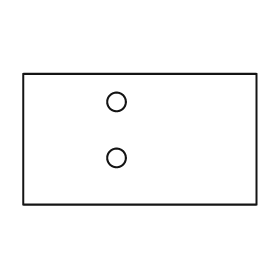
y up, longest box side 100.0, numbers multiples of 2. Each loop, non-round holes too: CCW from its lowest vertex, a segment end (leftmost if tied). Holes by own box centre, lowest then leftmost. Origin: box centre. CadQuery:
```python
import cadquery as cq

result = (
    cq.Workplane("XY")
    .moveTo(-50.0, -28.0)
    .lineTo(50.0, -28.0)
    .lineTo(50.0, 28.0)
    .lineTo(-50.0, 28.0)
    .close()
    .moveTo(-10.0, -8.0)
    .circle(4.0)
    .moveTo(-10.0, 16.0)
    .circle(4.0)
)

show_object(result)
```